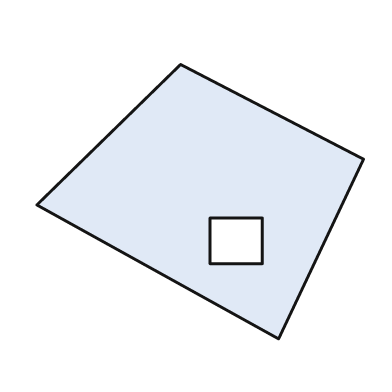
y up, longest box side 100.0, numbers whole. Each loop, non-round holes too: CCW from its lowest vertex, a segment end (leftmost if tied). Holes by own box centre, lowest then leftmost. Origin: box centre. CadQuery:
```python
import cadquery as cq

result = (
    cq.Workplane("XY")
    .moveTo(24.0, -42.0)
    .lineTo(50.0, 13.0)
    .lineTo(-6.0, 42.0)
    .lineTo(-50.0, -1.0)
    .close()
    .moveTo(3.0, -19.0)
    .lineTo(19.0, -19.0)
    .lineTo(19.0, -5.0)
    .lineTo(3.0, -5.0)
    .close()
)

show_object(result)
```